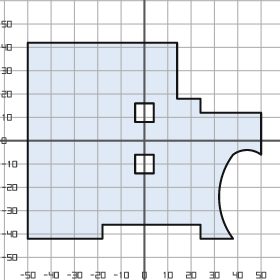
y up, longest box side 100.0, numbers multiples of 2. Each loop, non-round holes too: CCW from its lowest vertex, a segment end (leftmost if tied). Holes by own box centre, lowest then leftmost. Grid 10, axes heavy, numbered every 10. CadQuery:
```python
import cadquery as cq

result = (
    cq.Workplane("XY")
    .moveTo(-50.0, -42.0)
    .lineTo(-18.0, -42.0)
    .lineTo(-18.0, -36.0)
    .lineTo(24.0, -36.0)
    .lineTo(24.0, -42.0)
    .lineTo(38.0, -42.0)
    .threePointArc((32.0, -24.0), (38.0, -6.0))
    .threePointArc((44.0, -4.0), (50.0, -6.0))
    .lineTo(50.0, 12.0)
    .lineTo(24.0, 12.0)
    .lineTo(24.0, 18.0)
    .lineTo(14.0, 18.0)
    .lineTo(14.0, 42.0)
    .lineTo(-50.0, 42.0)
    .close()
    .moveTo(-4.0, -14.0)
    .lineTo(4.0, -14.0)
    .lineTo(4.0, -6.0)
    .lineTo(-4.0, -6.0)
    .close()
    .moveTo(-4.0, 8.0)
    .lineTo(4.0, 8.0)
    .lineTo(4.0, 16.0)
    .lineTo(-4.0, 16.0)
    .close()
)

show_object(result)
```